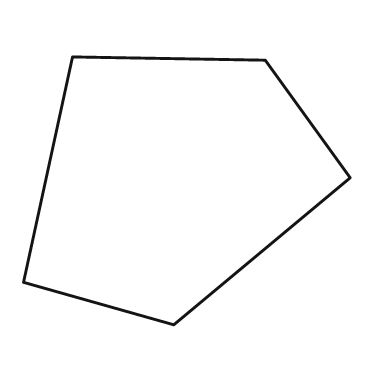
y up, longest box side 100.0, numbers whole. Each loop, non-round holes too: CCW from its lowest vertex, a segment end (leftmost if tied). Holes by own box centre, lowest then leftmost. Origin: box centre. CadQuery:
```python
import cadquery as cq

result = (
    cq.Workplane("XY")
    .moveTo(-4.0, -41.0)
    .lineTo(50.0, 4.0)
    .lineTo(24.0, 40.0)
    .lineTo(-35.0, 41.0)
    .lineTo(-50.0, -28.0)
    .close()
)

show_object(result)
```